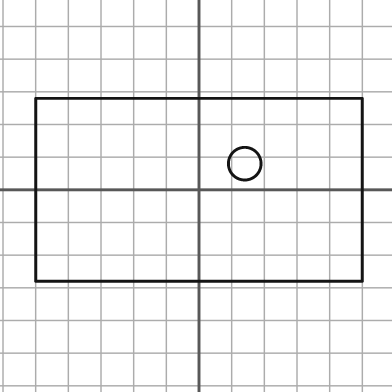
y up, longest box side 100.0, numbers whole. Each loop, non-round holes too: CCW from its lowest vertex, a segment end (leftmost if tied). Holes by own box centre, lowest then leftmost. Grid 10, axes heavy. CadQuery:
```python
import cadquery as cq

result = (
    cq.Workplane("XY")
    .moveTo(-50.0, -28.0)
    .lineTo(50.0, -28.0)
    .lineTo(50.0, 28.0)
    .lineTo(-50.0, 28.0)
    .close()
    .moveTo(14.0, 8.0)
    .circle(5.0)
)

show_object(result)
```